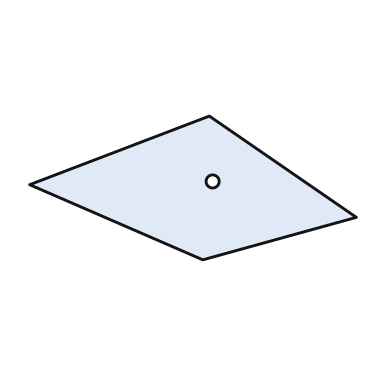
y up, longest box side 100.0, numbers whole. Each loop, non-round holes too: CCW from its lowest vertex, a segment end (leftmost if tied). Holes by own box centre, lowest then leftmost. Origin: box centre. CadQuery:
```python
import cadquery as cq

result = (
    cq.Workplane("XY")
    .moveTo(3.0, -22.0)
    .lineTo(50.0, -9.0)
    .lineTo(5.0, 22.0)
    .lineTo(-50.0, 1.0)
    .close()
    .moveTo(6.0, 2.0)
    .circle(2.0)
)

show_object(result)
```